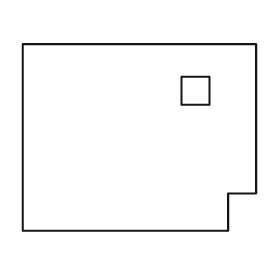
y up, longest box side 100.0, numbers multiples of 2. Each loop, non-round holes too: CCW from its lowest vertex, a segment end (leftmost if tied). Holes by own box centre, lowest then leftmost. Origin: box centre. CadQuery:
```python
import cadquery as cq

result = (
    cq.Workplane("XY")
    .moveTo(-50.0, -40.0)
    .lineTo(38.0, -40.0)
    .lineTo(38.0, -24.0)
    .lineTo(50.0, -24.0)
    .lineTo(50.0, 40.0)
    .lineTo(-50.0, 40.0)
    .close()
    .moveTo(18.0, 14.0)
    .lineTo(30.0, 14.0)
    .lineTo(30.0, 26.0)
    .lineTo(18.0, 26.0)
    .close()
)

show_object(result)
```